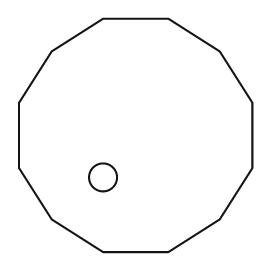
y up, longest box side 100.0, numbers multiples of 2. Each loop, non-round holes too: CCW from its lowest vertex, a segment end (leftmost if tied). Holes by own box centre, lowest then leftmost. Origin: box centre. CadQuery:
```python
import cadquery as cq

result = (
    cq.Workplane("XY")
    .moveTo(-14.0, -50.0)
    .lineTo(14.0, -50.0)
    .lineTo(36.0, -36.0)
    .lineTo(50.0, -14.0)
    .lineTo(50.0, 14.0)
    .lineTo(36.0, 36.0)
    .lineTo(14.0, 50.0)
    .lineTo(-14.0, 50.0)
    .lineTo(-36.0, 36.0)
    .lineTo(-50.0, 14.0)
    .lineTo(-50.0, -14.0)
    .lineTo(-36.0, -36.0)
    .close()
    .moveTo(-14.0, -18.0)
    .circle(6.0)
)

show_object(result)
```